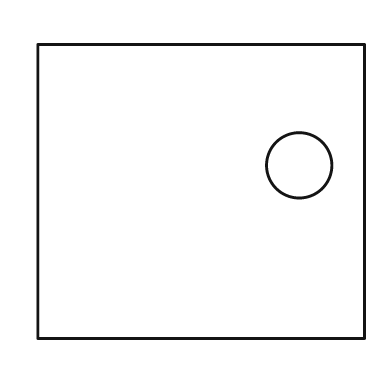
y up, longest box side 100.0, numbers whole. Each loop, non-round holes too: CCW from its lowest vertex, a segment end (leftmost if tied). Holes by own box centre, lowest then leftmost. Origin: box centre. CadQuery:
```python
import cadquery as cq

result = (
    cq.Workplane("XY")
    .moveTo(-50.0, -45.0)
    .lineTo(50.0, -45.0)
    .lineTo(50.0, 45.0)
    .lineTo(-50.0, 45.0)
    .close()
    .moveTo(30.0, 8.0)
    .circle(10.0)
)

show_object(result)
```